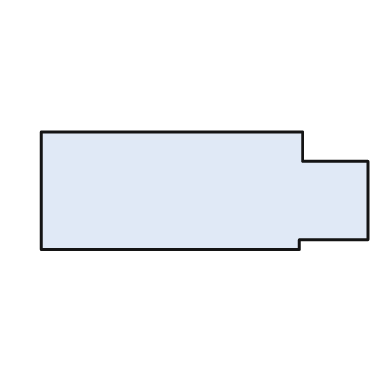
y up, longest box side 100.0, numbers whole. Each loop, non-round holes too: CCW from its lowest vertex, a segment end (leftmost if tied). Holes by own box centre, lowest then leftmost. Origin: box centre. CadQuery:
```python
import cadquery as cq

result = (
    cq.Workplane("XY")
    .moveTo(-50.0, -18.0)
    .lineTo(29.0, -18.0)
    .lineTo(29.0, -15.0)
    .lineTo(50.0, -15.0)
    .lineTo(50.0, 9.0)
    .lineTo(30.0, 9.0)
    .lineTo(30.0, 18.0)
    .lineTo(-50.0, 18.0)
    .close()
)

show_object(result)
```